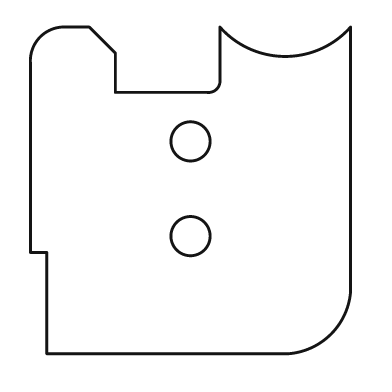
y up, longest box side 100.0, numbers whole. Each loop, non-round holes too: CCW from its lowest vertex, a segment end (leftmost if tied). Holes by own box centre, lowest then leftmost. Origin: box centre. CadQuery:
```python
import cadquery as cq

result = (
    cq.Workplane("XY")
    .moveTo(-44.0, -50.0)
    .lineTo(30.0, -50.0)
    .threePointArc((43.0, -44.0), (49.0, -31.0))
    .lineTo(49.0, 50.0)
    .threePointArc((29.0, 41.0), (9.0, 50.0))
    .lineTo(9.0, 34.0)
    .threePointArc((8.0, 31.0), (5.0, 30.0))
    .lineTo(-23.0, 30.0)
    .lineTo(-23.0, 42.0)
    .lineTo(-31.0, 50.0)
    .lineTo(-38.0, 50.0)
    .threePointArc((-46.0, 47.0), (-49.0, 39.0))
    .lineTo(-49.0, -19.0)
    .lineTo(-44.0, -19.0)
    .close()
    .moveTo(0.0, -14.0)
    .circle(6.0)
    .moveTo(0.0, 15.0)
    .circle(6.0)
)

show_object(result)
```